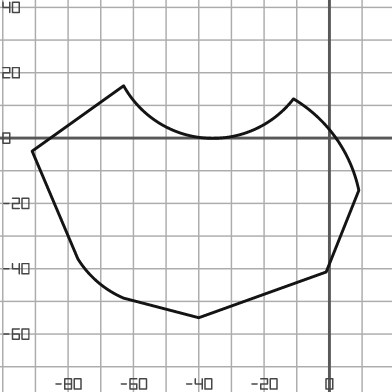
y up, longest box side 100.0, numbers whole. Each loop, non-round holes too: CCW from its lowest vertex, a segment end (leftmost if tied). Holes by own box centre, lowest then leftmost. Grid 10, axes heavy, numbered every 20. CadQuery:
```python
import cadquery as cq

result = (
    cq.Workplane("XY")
    .moveTo(-40.0, -55.0)
    .lineTo(-1.0, -41.0)
    .lineTo(9.0, -16.0)
    .threePointArc((2.0, 0.0), (-11.0, 12.0))
    .threePointArc((-38.0, 0.0), (-63.0, 16.0))
    .lineTo(-91.0, -4.0)
    .lineTo(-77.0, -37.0)
    .threePointArc((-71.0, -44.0), (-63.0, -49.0))
    .close()
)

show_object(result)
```